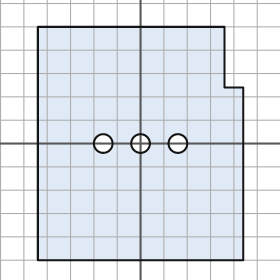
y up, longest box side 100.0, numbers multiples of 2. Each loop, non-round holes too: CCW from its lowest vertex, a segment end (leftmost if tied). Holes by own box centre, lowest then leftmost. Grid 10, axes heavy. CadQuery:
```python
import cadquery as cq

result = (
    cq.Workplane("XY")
    .moveTo(-44.0, -50.0)
    .lineTo(44.0, -50.0)
    .lineTo(44.0, 24.0)
    .lineTo(36.0, 24.0)
    .lineTo(36.0, 50.0)
    .lineTo(-44.0, 50.0)
    .close()
    .moveTo(-16.0, 0.0)
    .circle(4.0)
    .moveTo(0.0, 0.0)
    .circle(4.0)
    .moveTo(16.0, 0.0)
    .circle(4.0)
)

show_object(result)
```